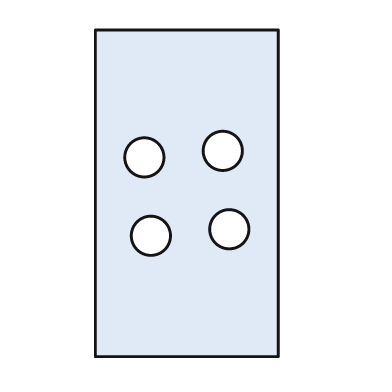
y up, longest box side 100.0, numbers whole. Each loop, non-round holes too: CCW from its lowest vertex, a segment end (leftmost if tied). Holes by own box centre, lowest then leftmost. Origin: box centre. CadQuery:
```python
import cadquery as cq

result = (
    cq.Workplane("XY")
    .moveTo(-28.0, -50.0)
    .lineTo(28.0, -50.0)
    .lineTo(28.0, 50.0)
    .lineTo(-28.0, 50.0)
    .close()
    .moveTo(-11.0, -13.0)
    .circle(6.0)
    .moveTo(13.0, -11.0)
    .circle(6.0)
    .moveTo(-13.0, 11.0)
    .circle(6.0)
    .moveTo(11.0, 13.0)
    .circle(6.0)
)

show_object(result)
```